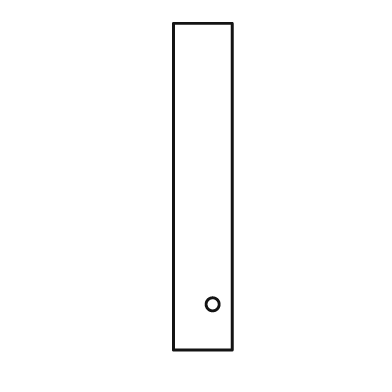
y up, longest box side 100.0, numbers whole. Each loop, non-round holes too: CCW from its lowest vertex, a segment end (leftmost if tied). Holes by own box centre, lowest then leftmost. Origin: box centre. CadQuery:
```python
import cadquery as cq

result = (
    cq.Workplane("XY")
    .moveTo(-9.0, -50.0)
    .lineTo(9.0, -50.0)
    .lineTo(9.0, 50.0)
    .lineTo(-9.0, 50.0)
    .close()
    .moveTo(3.0, -36.0)
    .circle(2.0)
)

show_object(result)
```